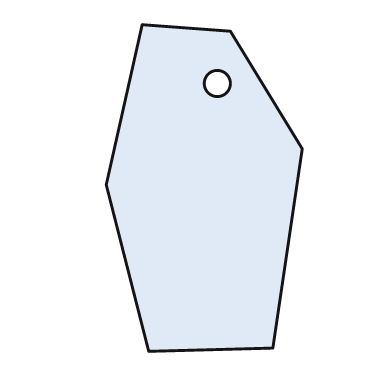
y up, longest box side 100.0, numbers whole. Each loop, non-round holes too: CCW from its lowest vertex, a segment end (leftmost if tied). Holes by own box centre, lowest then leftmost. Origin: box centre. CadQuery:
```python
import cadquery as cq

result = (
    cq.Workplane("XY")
    .moveTo(-17.0, -50.0)
    .lineTo(21.0, -49.0)
    .lineTo(30.0, 12.0)
    .lineTo(8.0, 48.0)
    .lineTo(-19.0, 50.0)
    .lineTo(-30.0, 1.0)
    .close()
    .moveTo(4.0, 32.0)
    .circle(4.0)
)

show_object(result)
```